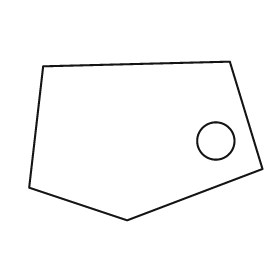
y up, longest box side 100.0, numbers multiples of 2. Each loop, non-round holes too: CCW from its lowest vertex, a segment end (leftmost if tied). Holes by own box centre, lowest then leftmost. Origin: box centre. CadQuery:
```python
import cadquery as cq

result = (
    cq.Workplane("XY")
    .moveTo(-8.0, -34.0)
    .lineTo(50.0, -12.0)
    .lineTo(36.0, 34.0)
    .lineTo(-44.0, 32.0)
    .lineTo(-50.0, -20.0)
    .close()
    .moveTo(30.0, 0.0)
    .circle(8.0)
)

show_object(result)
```